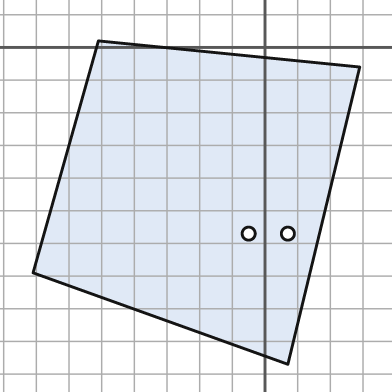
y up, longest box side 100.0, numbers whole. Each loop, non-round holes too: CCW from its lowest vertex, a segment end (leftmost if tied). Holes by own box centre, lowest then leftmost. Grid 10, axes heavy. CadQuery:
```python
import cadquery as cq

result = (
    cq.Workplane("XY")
    .moveTo(7.0, -97.0)
    .lineTo(29.0, -6.0)
    .lineTo(-51.0, 2.0)
    .lineTo(-71.0, -69.0)
    .close()
    .moveTo(-5.0, -57.0)
    .circle(2.0)
    .moveTo(7.0, -57.0)
    .circle(2.0)
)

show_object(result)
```